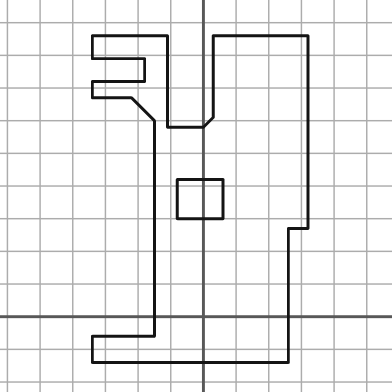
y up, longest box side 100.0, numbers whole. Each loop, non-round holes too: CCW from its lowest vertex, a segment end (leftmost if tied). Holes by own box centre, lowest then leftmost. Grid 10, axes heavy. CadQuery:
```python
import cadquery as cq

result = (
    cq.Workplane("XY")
    .moveTo(-34.0, -14.0)
    .lineTo(26.0, -14.0)
    .lineTo(26.0, 27.0)
    .lineTo(32.0, 27.0)
    .lineTo(32.0, 86.0)
    .lineTo(3.0, 86.0)
    .lineTo(3.0, 61.0)
    .lineTo(0.0, 58.0)
    .lineTo(-11.0, 58.0)
    .lineTo(-11.0, 86.0)
    .lineTo(-34.0, 86.0)
    .lineTo(-34.0, 79.0)
    .lineTo(-18.0, 79.0)
    .lineTo(-18.0, 72.0)
    .lineTo(-34.0, 72.0)
    .lineTo(-34.0, 67.0)
    .lineTo(-22.0, 67.0)
    .lineTo(-15.0, 60.0)
    .lineTo(-15.0, -6.0)
    .lineTo(-34.0, -6.0)
    .close()
    .moveTo(-8.0, 30.0)
    .lineTo(6.0, 30.0)
    .lineTo(6.0, 42.0)
    .lineTo(-8.0, 42.0)
    .close()
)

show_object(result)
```